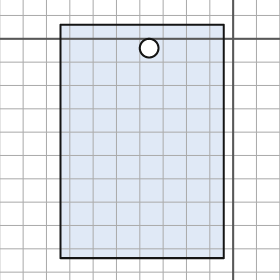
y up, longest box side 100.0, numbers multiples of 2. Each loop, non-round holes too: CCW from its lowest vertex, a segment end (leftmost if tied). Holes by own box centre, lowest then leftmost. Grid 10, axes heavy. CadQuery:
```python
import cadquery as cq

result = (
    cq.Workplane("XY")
    .moveTo(-74.0, -94.0)
    .lineTo(-4.0, -94.0)
    .lineTo(-4.0, 6.0)
    .lineTo(-74.0, 6.0)
    .close()
    .moveTo(-36.0, -4.0)
    .circle(4.0)
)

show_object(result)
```